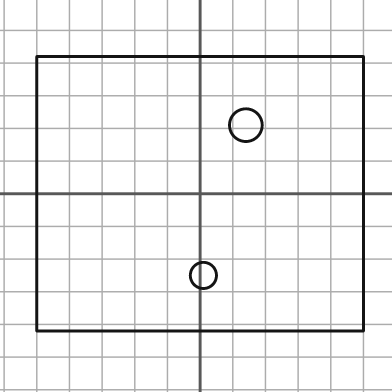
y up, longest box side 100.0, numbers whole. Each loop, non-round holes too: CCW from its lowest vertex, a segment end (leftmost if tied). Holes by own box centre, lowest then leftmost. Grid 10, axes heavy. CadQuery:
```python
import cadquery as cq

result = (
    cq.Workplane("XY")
    .moveTo(-50.0, -42.0)
    .lineTo(50.0, -42.0)
    .lineTo(50.0, 42.0)
    .lineTo(-50.0, 42.0)
    .close()
    .moveTo(1.0, -25.0)
    .circle(4.0)
    .moveTo(14.0, 21.0)
    .circle(5.0)
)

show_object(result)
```